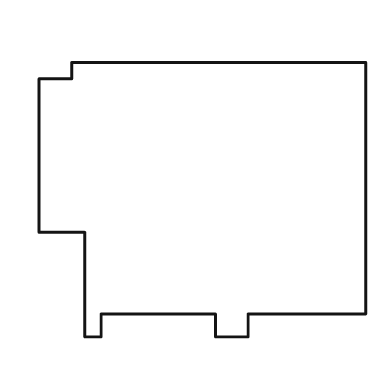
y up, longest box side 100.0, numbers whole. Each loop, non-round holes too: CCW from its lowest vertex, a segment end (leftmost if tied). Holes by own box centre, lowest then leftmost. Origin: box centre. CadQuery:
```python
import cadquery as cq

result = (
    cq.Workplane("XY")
    .moveTo(-36.0, -42.0)
    .lineTo(-31.0, -42.0)
    .lineTo(-31.0, -35.0)
    .lineTo(4.0, -35.0)
    .lineTo(4.0, -42.0)
    .lineTo(14.0, -42.0)
    .lineTo(14.0, -35.0)
    .lineTo(50.0, -35.0)
    .lineTo(50.0, 42.0)
    .lineTo(-40.0, 42.0)
    .lineTo(-40.0, 37.0)
    .lineTo(-50.0, 37.0)
    .lineTo(-50.0, -10.0)
    .lineTo(-36.0, -10.0)
    .close()
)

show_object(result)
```